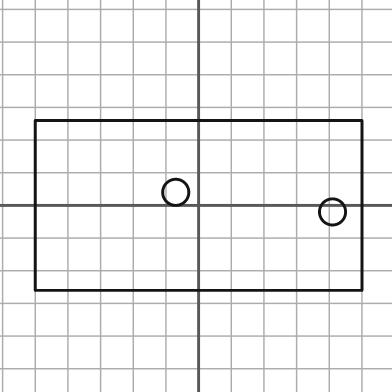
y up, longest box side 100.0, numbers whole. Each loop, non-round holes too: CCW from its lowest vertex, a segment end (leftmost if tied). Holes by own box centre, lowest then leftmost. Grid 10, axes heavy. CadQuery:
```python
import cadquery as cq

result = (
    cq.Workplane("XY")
    .moveTo(-50.0, -26.0)
    .lineTo(50.0, -26.0)
    .lineTo(50.0, 26.0)
    .lineTo(-50.0, 26.0)
    .close()
    .moveTo(41.0, -2.0)
    .circle(4.0)
    .moveTo(-7.0, 4.0)
    .circle(4.0)
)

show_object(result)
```